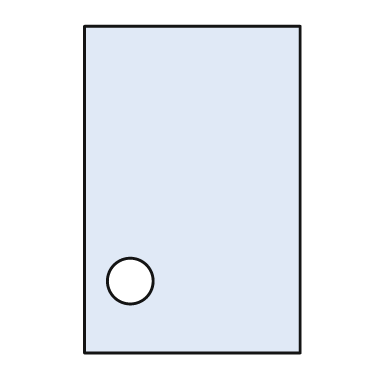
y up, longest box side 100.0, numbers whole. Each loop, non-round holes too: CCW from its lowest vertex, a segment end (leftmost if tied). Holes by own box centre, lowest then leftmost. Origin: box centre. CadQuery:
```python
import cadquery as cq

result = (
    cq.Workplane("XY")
    .moveTo(-33.0, -50.0)
    .lineTo(33.0, -50.0)
    .lineTo(33.0, 50.0)
    .lineTo(-33.0, 50.0)
    .close()
    .moveTo(-19.0, -28.0)
    .circle(7.0)
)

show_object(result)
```